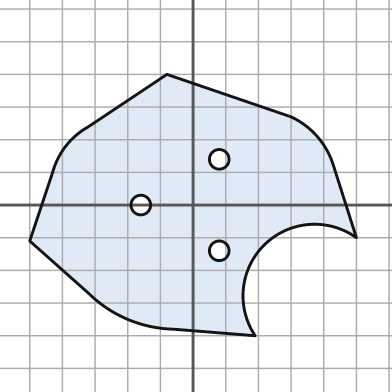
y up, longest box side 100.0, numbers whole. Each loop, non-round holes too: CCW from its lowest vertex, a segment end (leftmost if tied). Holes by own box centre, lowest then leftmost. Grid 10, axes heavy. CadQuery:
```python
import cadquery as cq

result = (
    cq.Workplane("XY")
    .moveTo(19.0, -40.0)
    .threePointArc((22.0, -12.0), (50.0, -10.0))
    .lineTo(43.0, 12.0)
    .threePointArc((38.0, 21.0), (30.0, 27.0))
    .lineTo(-8.0, 40.0)
    .lineTo(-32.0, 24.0)
    .threePointArc((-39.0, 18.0), (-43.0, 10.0))
    .lineTo(-50.0, -11.0)
    .lineTo(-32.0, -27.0)
    .threePointArc((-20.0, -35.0), (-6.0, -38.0))
    .close()
    .moveTo(8.0, -14.0)
    .circle(3.0)
    .moveTo(-16.0, 0.0)
    .circle(3.0)
    .moveTo(8.0, 14.0)
    .circle(3.0)
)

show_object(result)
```